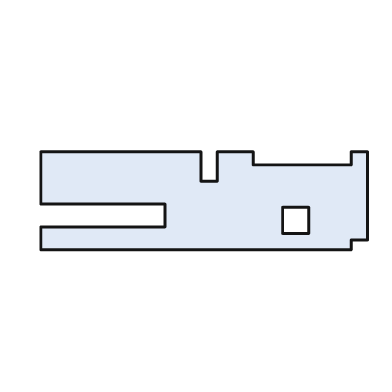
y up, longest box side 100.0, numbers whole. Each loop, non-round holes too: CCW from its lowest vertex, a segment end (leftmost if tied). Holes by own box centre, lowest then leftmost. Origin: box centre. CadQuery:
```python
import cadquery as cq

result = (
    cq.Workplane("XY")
    .moveTo(-50.0, -15.0)
    .lineTo(45.0, -15.0)
    .lineTo(45.0, -12.0)
    .lineTo(50.0, -12.0)
    .lineTo(50.0, 15.0)
    .lineTo(45.0, 15.0)
    .lineTo(45.0, 11.0)
    .lineTo(15.0, 11.0)
    .lineTo(15.0, 15.0)
    .lineTo(4.0, 15.0)
    .lineTo(4.0, 6.0)
    .lineTo(-1.0, 6.0)
    .lineTo(-1.0, 15.0)
    .lineTo(-50.0, 15.0)
    .lineTo(-50.0, -1.0)
    .lineTo(-12.0, -1.0)
    .lineTo(-12.0, -8.0)
    .lineTo(-50.0, -8.0)
    .close()
    .moveTo(24.0, -10.0)
    .lineTo(32.0, -10.0)
    .lineTo(32.0, -2.0)
    .lineTo(24.0, -2.0)
    .close()
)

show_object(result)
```